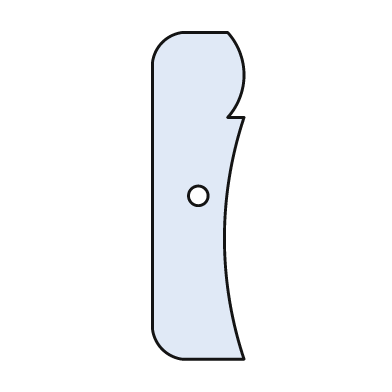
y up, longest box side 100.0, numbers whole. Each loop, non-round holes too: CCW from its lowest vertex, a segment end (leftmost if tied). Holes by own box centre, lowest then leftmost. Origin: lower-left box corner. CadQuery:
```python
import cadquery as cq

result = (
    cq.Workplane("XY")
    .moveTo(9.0, 0.0)
    .lineTo(28.0, 0.0)
    .threePointArc((22.0, 37.0), (28.0, 74.0))
    .lineTo(23.0, 74.0)
    .threePointArc((28.0, 87.0), (23.0, 100.0))
    .lineTo(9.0, 100.0)
    .threePointArc((3.0, 97.0), (0.0, 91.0))
    .lineTo(0.0, 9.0)
    .threePointArc((3.0, 3.0), (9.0, 0.0))
    .close()
    .moveTo(14.0, 50.0)
    .circle(3.0)
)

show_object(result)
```